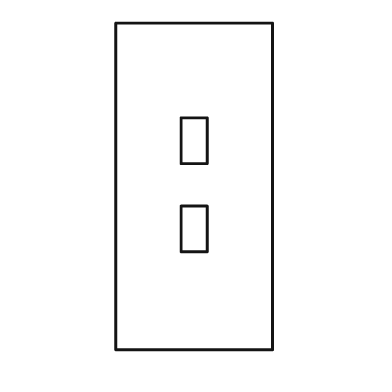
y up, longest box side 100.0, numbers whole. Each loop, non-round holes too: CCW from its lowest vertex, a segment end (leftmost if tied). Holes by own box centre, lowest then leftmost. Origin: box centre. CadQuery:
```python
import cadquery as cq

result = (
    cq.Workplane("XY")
    .moveTo(-24.0, -50.0)
    .lineTo(24.0, -50.0)
    .lineTo(24.0, 50.0)
    .lineTo(-24.0, 50.0)
    .close()
    .moveTo(-4.0, -20.0)
    .lineTo(4.0, -20.0)
    .lineTo(4.0, -6.0)
    .lineTo(-4.0, -6.0)
    .close()
    .moveTo(-4.0, 7.0)
    .lineTo(4.0, 7.0)
    .lineTo(4.0, 21.0)
    .lineTo(-4.0, 21.0)
    .close()
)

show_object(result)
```